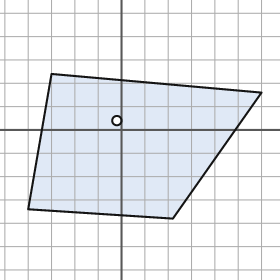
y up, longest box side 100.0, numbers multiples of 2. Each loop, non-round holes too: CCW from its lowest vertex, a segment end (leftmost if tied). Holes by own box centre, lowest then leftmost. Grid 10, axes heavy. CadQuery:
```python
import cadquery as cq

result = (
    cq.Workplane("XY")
    .moveTo(22.0, -38.0)
    .lineTo(60.0, 16.0)
    .lineTo(-30.0, 24.0)
    .lineTo(-40.0, -34.0)
    .close()
    .moveTo(-2.0, 4.0)
    .circle(2.0)
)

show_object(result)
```